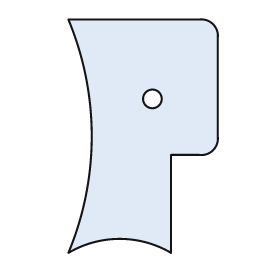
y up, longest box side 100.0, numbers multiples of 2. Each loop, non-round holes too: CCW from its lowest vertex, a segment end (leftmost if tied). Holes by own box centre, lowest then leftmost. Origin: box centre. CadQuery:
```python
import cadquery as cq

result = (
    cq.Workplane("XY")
    .moveTo(-32.0, -50.0)
    .threePointArc((-10.0, -44.0), (12.0, -50.0))
    .lineTo(12.0, -8.0)
    .lineTo(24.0, -8.0)
    .threePointArc((30.0, -6.0), (32.0, 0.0))
    .lineTo(32.0, 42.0)
    .threePointArc((30.0, 48.0), (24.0, 50.0))
    .lineTo(-32.0, 50.0)
    .threePointArc((-22.0, 0.0), (-32.0, -50.0))
    .close()
    .moveTo(4.0, 16.0)
    .circle(4.0)
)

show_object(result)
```